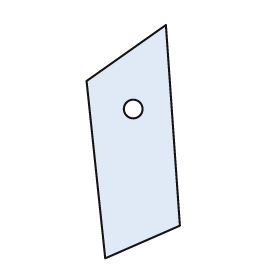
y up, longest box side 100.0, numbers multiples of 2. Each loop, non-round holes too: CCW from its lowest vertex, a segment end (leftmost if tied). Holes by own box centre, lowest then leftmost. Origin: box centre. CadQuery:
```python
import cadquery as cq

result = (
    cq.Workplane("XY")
    .moveTo(-12.0, -50.0)
    .lineTo(20.0, -36.0)
    .lineTo(14.0, 50.0)
    .lineTo(-20.0, 26.0)
    .close()
    .moveTo(0.0, 14.0)
    .circle(4.0)
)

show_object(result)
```